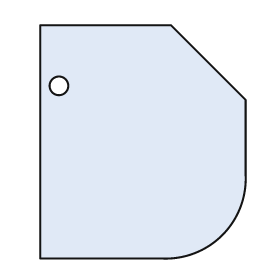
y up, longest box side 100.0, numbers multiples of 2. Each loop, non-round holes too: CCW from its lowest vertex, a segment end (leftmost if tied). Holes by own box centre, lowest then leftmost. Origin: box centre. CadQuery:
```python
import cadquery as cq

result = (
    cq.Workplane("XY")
    .moveTo(-44.0, -50.0)
    .lineTo(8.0, -50.0)
    .threePointArc((34.0, -40.0), (44.0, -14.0))
    .lineTo(44.0, 18.0)
    .lineTo(12.0, 50.0)
    .lineTo(-44.0, 50.0)
    .close()
    .moveTo(-36.0, 24.0)
    .circle(4.0)
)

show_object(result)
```